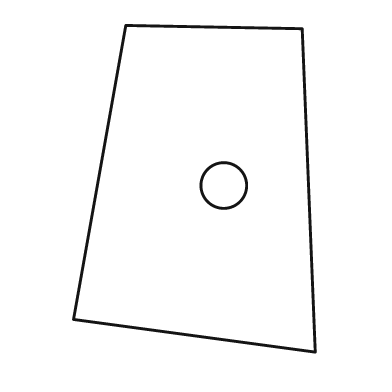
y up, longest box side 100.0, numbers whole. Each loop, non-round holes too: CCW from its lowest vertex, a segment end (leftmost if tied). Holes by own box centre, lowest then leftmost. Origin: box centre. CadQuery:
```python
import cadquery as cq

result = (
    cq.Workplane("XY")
    .moveTo(37.0, -50.0)
    .lineTo(33.0, 49.0)
    .lineTo(-21.0, 50.0)
    .lineTo(-37.0, -40.0)
    .close()
    .moveTo(9.0, 1.0)
    .circle(7.0)
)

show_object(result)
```